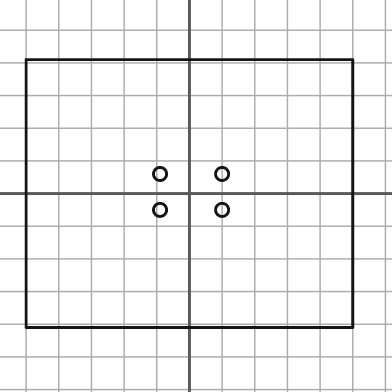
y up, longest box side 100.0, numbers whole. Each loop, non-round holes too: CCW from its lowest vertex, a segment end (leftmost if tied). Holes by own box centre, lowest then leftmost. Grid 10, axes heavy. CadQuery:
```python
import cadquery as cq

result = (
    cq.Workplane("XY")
    .moveTo(-50.0, -41.0)
    .lineTo(50.0, -41.0)
    .lineTo(50.0, 41.0)
    .lineTo(-50.0, 41.0)
    .close()
    .moveTo(-9.0, -5.0)
    .circle(2.0)
    .moveTo(10.0, -5.0)
    .circle(2.0)
    .moveTo(-9.0, 6.0)
    .circle(2.0)
    .moveTo(10.0, 6.0)
    .circle(2.0)
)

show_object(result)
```